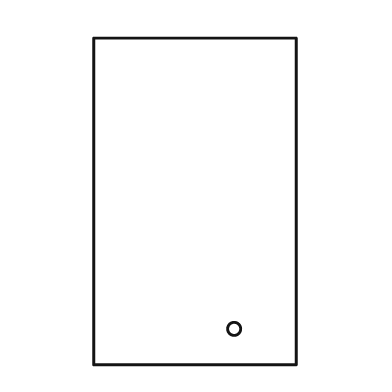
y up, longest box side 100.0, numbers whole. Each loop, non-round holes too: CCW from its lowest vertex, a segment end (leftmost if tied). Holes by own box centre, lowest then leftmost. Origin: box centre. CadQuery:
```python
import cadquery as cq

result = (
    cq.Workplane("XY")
    .moveTo(-31.0, -50.0)
    .lineTo(31.0, -50.0)
    .lineTo(31.0, 50.0)
    .lineTo(-31.0, 50.0)
    .close()
    .moveTo(12.0, -39.0)
    .circle(2.0)
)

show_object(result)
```